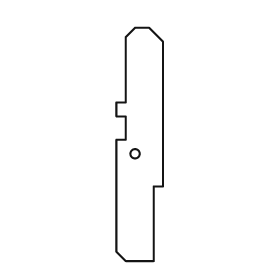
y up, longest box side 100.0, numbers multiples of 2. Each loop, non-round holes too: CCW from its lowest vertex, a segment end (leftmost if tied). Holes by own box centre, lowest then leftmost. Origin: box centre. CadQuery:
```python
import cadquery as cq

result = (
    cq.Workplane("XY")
    .moveTo(-6.0, -50.0)
    .lineTo(6.0, -50.0)
    .lineTo(6.0, -18.0)
    .lineTo(10.0, -18.0)
    .lineTo(10.0, 44.0)
    .lineTo(4.0, 50.0)
    .lineTo(-2.0, 50.0)
    .lineTo(-6.0, 46.0)
    .lineTo(-6.0, 18.0)
    .lineTo(-10.0, 18.0)
    .lineTo(-10.0, 12.0)
    .lineTo(-6.0, 12.0)
    .lineTo(-6.0, 2.0)
    .lineTo(-10.0, 2.0)
    .lineTo(-10.0, -46.0)
    .close()
    .moveTo(-2.0, -4.0)
    .circle(2.0)
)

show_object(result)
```